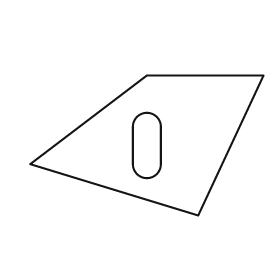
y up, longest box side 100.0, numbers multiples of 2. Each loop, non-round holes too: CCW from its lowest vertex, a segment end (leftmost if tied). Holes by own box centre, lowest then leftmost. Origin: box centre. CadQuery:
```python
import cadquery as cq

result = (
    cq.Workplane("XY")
    .moveTo(22.0, -30.0)
    .lineTo(50.0, 30.0)
    .lineTo(0.0, 30.0)
    .lineTo(-50.0, -8.0)
    .close()
    .moveTo(-6.0, -8.0)
    .threePointArc((0.0, -14.0), (6.0, -8.0))
    .lineTo(6.0, 8.0)
    .threePointArc((0.0, 14.0), (-6.0, 8.0))
    .close()
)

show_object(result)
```